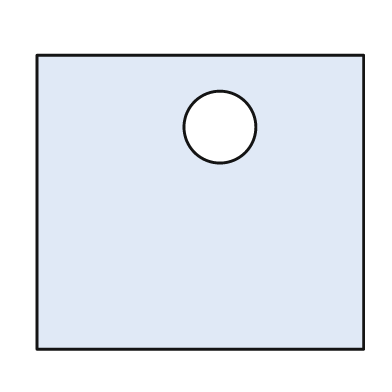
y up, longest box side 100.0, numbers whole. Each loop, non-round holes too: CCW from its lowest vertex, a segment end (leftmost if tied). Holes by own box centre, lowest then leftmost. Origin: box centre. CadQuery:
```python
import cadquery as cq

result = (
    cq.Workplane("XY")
    .moveTo(-50.0, -45.0)
    .lineTo(50.0, -45.0)
    .lineTo(50.0, 45.0)
    .lineTo(-50.0, 45.0)
    .close()
    .moveTo(6.0, 23.0)
    .circle(11.0)
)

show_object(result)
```